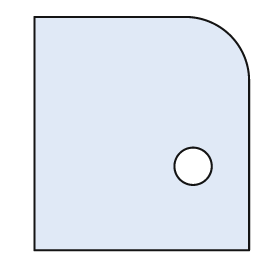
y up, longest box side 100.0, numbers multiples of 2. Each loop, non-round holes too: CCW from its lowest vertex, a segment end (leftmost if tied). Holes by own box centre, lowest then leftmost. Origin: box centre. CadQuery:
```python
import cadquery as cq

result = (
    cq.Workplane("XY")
    .moveTo(-46.0, -50.0)
    .lineTo(46.0, -50.0)
    .lineTo(46.0, 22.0)
    .threePointArc((38.0, 42.0), (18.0, 50.0))
    .lineTo(-46.0, 50.0)
    .close()
    .moveTo(22.0, -14.0)
    .circle(8.0)
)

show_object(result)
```